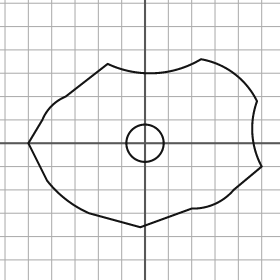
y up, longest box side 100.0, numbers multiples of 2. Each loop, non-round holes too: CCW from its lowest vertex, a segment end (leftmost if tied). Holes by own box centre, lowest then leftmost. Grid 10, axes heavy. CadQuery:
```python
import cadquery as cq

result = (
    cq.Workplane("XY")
    .moveTo(-2.0, -36.0)
    .lineTo(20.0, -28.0)
    .threePointArc((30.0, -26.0), (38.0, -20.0))
    .lineTo(50.0, -10.0)
    .threePointArc((46.0, 4.0), (48.0, 18.0))
    .threePointArc((38.0, 30.0), (24.0, 36.0))
    .threePointArc((4.0, 30.0), (-16.0, 34.0))
    .lineTo(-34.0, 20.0)
    .threePointArc((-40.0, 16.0), (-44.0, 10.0))
    .lineTo(-50.0, 0.0)
    .lineTo(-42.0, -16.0)
    .threePointArc((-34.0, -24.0), (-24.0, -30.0))
    .close()
    .moveTo(0.0, 0.0)
    .circle(8.0)
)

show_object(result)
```